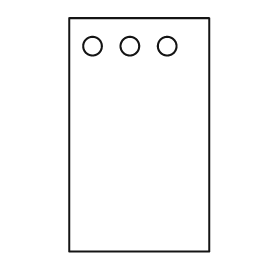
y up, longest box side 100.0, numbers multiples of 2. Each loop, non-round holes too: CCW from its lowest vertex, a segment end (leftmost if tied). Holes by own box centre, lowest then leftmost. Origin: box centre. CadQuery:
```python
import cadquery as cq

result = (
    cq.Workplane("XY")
    .moveTo(-30.0, -50.0)
    .lineTo(30.0, -50.0)
    .lineTo(30.0, 50.0)
    .lineTo(-30.0, 50.0)
    .close()
    .moveTo(-20.0, 38.0)
    .circle(4.0)
    .moveTo(-4.0, 38.0)
    .circle(4.0)
    .moveTo(12.0, 38.0)
    .circle(4.0)
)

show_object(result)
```